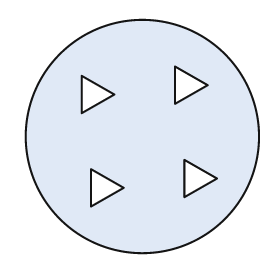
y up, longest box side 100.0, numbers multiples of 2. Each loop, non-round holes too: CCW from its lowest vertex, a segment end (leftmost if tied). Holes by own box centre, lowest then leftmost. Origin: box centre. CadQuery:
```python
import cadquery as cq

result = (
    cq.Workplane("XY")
    .moveTo(0.0, 0.0)
    .circle(50.0)
    .moveTo(-22.0, -30.0)
    .lineTo(-8.0, -22.0)
    .lineTo(-22.0, -14.0)
    .close()
    .moveTo(18.0, -26.0)
    .lineTo(32.0, -18.0)
    .lineTo(18.0, -10.0)
    .close()
    .moveTo(-26.0, 10.0)
    .lineTo(-12.0, 18.0)
    .lineTo(-26.0, 26.0)
    .close()
    .moveTo(14.0, 14.0)
    .lineTo(28.0, 22.0)
    .lineTo(14.0, 30.0)
    .close()
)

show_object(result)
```